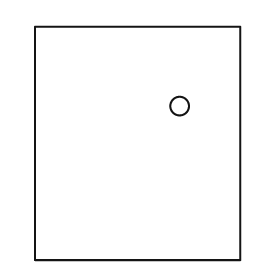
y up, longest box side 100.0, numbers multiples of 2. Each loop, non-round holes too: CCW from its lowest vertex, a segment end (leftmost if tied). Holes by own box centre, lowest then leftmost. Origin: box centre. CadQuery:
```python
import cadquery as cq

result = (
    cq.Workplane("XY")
    .moveTo(-44.0, -50.0)
    .lineTo(44.0, -50.0)
    .lineTo(44.0, 50.0)
    .lineTo(-44.0, 50.0)
    .close()
    .moveTo(18.0, 16.0)
    .circle(4.0)
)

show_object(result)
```